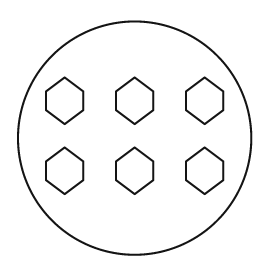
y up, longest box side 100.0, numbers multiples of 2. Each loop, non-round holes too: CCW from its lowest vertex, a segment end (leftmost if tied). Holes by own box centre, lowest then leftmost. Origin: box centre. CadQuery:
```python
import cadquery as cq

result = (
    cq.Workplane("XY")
    .moveTo(0.0, 0.0)
    .circle(50.0)
    .moveTo(-30.0, -24.0)
    .lineTo(-22.0, -18.0)
    .lineTo(-22.0, -10.0)
    .lineTo(-30.0, -4.0)
    .lineTo(-38.0, -10.0)
    .lineTo(-38.0, -18.0)
    .close()
    .moveTo(0.0, -24.0)
    .lineTo(8.0, -18.0)
    .lineTo(8.0, -10.0)
    .lineTo(0.0, -4.0)
    .lineTo(-8.0, -10.0)
    .lineTo(-8.0, -18.0)
    .close()
    .moveTo(30.0, -24.0)
    .lineTo(38.0, -18.0)
    .lineTo(38.0, -10.0)
    .lineTo(30.0, -4.0)
    .lineTo(22.0, -10.0)
    .lineTo(22.0, -18.0)
    .close()
    .moveTo(-30.0, 6.0)
    .lineTo(-22.0, 12.0)
    .lineTo(-22.0, 20.0)
    .lineTo(-30.0, 26.0)
    .lineTo(-38.0, 20.0)
    .lineTo(-38.0, 12.0)
    .close()
    .moveTo(0.0, 6.0)
    .lineTo(8.0, 12.0)
    .lineTo(8.0, 20.0)
    .lineTo(0.0, 26.0)
    .lineTo(-8.0, 20.0)
    .lineTo(-8.0, 12.0)
    .close()
    .moveTo(30.0, 6.0)
    .lineTo(38.0, 12.0)
    .lineTo(38.0, 20.0)
    .lineTo(30.0, 26.0)
    .lineTo(22.0, 20.0)
    .lineTo(22.0, 12.0)
    .close()
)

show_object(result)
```